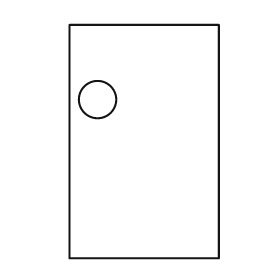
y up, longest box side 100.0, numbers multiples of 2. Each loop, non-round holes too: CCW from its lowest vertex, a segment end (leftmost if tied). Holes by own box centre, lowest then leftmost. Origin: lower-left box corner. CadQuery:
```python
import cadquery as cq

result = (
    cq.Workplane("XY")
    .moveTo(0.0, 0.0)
    .lineTo(64.0, 0.0)
    .lineTo(64.0, 100.0)
    .lineTo(0.0, 100.0)
    .close()
    .moveTo(12.0, 68.0)
    .circle(8.0)
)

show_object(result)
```